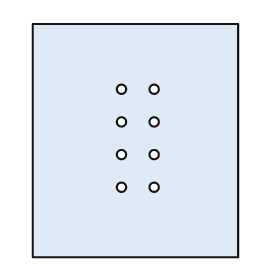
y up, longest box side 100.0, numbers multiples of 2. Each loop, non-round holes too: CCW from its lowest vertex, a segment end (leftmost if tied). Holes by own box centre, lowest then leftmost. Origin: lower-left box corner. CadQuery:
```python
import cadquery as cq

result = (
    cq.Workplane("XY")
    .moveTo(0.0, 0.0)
    .lineTo(88.0, 0.0)
    .lineTo(88.0, 100.0)
    .lineTo(0.0, 100.0)
    .close()
    .moveTo(38.0, 30.0)
    .circle(2.0)
    .moveTo(52.0, 30.0)
    .circle(2.0)
    .moveTo(38.0, 44.0)
    .circle(2.0)
    .moveTo(52.0, 44.0)
    .circle(2.0)
    .moveTo(38.0, 58.0)
    .circle(2.0)
    .moveTo(52.0, 58.0)
    .circle(2.0)
    .moveTo(38.0, 72.0)
    .circle(2.0)
    .moveTo(52.0, 72.0)
    .circle(2.0)
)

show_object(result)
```